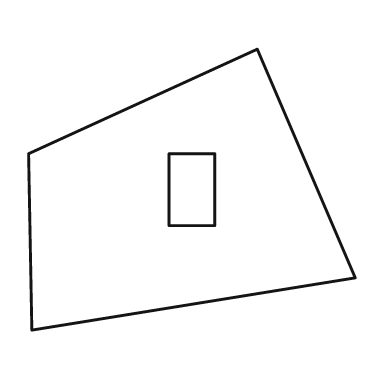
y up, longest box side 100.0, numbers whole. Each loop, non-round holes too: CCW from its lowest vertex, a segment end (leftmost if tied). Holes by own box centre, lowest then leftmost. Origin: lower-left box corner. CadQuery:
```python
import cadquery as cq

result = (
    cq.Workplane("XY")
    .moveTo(1.0, 0.0)
    .lineTo(100.0, 16.0)
    .lineTo(70.0, 86.0)
    .lineTo(0.0, 54.0)
    .close()
    .moveTo(43.0, 32.0)
    .lineTo(57.0, 32.0)
    .lineTo(57.0, 54.0)
    .lineTo(43.0, 54.0)
    .close()
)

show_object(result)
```